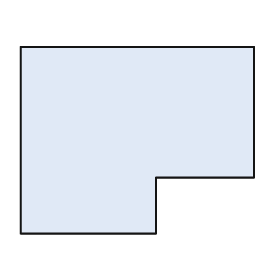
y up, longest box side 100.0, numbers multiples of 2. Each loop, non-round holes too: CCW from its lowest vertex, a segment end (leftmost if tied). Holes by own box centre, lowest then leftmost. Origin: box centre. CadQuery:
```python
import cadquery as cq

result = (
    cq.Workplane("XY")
    .moveTo(-50.0, -40.0)
    .lineTo(8.0, -40.0)
    .lineTo(8.0, -16.0)
    .lineTo(50.0, -16.0)
    .lineTo(50.0, 40.0)
    .lineTo(-50.0, 40.0)
    .close()
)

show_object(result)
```